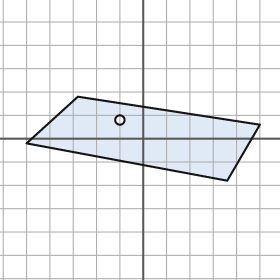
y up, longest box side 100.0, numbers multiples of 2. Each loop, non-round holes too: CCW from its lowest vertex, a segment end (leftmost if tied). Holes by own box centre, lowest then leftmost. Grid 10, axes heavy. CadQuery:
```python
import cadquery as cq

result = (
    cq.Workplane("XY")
    .moveTo(36.0, -18.0)
    .lineTo(50.0, 6.0)
    .lineTo(-28.0, 18.0)
    .lineTo(-50.0, -2.0)
    .close()
    .moveTo(-10.0, 8.0)
    .circle(2.0)
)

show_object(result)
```